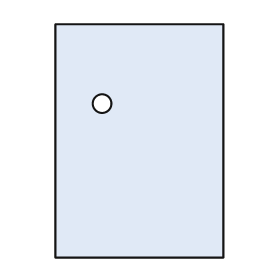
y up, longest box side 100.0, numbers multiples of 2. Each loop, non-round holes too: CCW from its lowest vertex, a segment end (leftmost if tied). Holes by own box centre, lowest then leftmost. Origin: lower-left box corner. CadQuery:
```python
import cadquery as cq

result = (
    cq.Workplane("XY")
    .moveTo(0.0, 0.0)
    .lineTo(72.0, 0.0)
    .lineTo(72.0, 100.0)
    .lineTo(0.0, 100.0)
    .close()
    .moveTo(20.0, 66.0)
    .circle(4.0)
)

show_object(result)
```